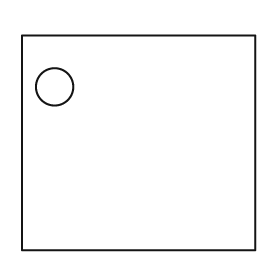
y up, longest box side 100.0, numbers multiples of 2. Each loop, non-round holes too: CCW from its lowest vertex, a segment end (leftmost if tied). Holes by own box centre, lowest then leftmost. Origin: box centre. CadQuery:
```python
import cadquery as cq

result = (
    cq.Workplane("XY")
    .moveTo(-50.0, -46.0)
    .lineTo(50.0, -46.0)
    .lineTo(50.0, 46.0)
    .lineTo(-50.0, 46.0)
    .close()
    .moveTo(-36.0, 24.0)
    .circle(8.0)
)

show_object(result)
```